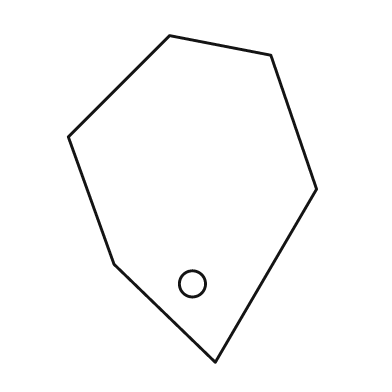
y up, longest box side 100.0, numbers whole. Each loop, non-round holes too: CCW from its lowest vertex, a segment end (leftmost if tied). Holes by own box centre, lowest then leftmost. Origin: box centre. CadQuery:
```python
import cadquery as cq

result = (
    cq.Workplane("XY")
    .moveTo(7.0, -50.0)
    .lineTo(38.0, 3.0)
    .lineTo(24.0, 44.0)
    .lineTo(-7.0, 50.0)
    .lineTo(-38.0, 19.0)
    .lineTo(-24.0, -20.0)
    .close()
    .moveTo(0.0, -26.0)
    .circle(4.0)
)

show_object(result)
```